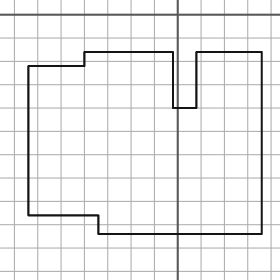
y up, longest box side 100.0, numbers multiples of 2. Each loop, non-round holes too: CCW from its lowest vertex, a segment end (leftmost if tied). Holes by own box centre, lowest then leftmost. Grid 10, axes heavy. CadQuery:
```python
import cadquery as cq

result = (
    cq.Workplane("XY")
    .moveTo(-34.0, -94.0)
    .lineTo(36.0, -94.0)
    .lineTo(36.0, -16.0)
    .lineTo(8.0, -16.0)
    .lineTo(8.0, -40.0)
    .lineTo(-2.0, -40.0)
    .lineTo(-2.0, -16.0)
    .lineTo(-40.0, -16.0)
    .lineTo(-40.0, -22.0)
    .lineTo(-64.0, -22.0)
    .lineTo(-64.0, -86.0)
    .lineTo(-34.0, -86.0)
    .close()
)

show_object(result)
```